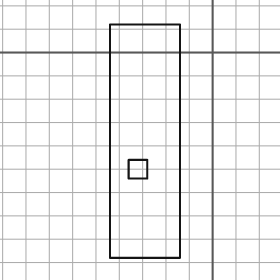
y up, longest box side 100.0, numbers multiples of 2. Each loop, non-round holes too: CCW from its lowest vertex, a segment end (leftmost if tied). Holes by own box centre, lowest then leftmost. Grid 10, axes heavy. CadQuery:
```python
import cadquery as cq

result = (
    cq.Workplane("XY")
    .moveTo(-44.0, -88.0)
    .lineTo(-14.0, -88.0)
    .lineTo(-14.0, 12.0)
    .lineTo(-44.0, 12.0)
    .close()
    .moveTo(-36.0, -54.0)
    .lineTo(-28.0, -54.0)
    .lineTo(-28.0, -46.0)
    .lineTo(-36.0, -46.0)
    .close()
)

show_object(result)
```